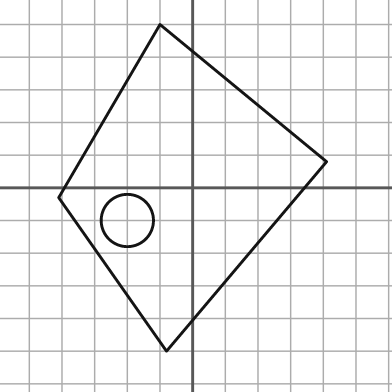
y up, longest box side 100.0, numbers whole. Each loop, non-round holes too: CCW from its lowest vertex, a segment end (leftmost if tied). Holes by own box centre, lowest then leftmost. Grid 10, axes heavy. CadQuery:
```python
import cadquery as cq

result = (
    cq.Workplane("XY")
    .moveTo(-8.0, -50.0)
    .lineTo(41.0, 8.0)
    .lineTo(-10.0, 50.0)
    .lineTo(-41.0, -3.0)
    .close()
    .moveTo(-20.0, -10.0)
    .circle(8.0)
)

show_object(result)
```